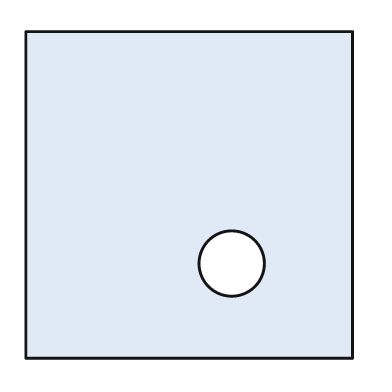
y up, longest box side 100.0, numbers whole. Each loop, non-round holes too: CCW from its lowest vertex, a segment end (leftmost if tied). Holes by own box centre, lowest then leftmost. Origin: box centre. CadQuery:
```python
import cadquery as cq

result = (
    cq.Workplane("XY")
    .moveTo(-50.0, -50.0)
    .lineTo(50.0, -50.0)
    .lineTo(50.0, 50.0)
    .lineTo(-50.0, 50.0)
    .close()
    .moveTo(13.0, -21.0)
    .circle(10.0)
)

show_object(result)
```